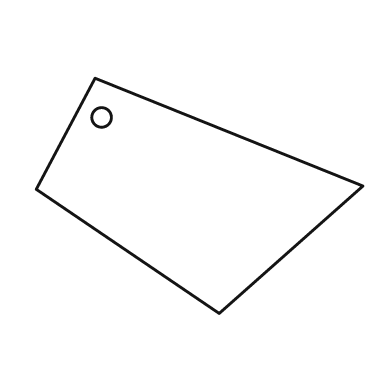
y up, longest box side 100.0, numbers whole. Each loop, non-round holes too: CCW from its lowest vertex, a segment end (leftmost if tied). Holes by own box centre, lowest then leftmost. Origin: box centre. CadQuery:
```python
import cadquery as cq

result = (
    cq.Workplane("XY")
    .moveTo(6.0, -36.0)
    .lineTo(50.0, 3.0)
    .lineTo(-32.0, 36.0)
    .lineTo(-50.0, 2.0)
    .close()
    .moveTo(-30.0, 24.0)
    .circle(3.0)
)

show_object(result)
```